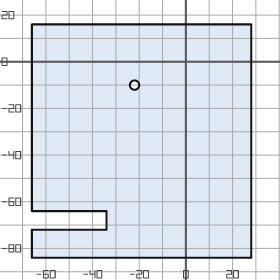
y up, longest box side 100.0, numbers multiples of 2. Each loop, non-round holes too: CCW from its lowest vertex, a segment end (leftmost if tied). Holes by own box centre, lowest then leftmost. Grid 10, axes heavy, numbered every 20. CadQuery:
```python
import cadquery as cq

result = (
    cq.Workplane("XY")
    .moveTo(-66.0, -84.0)
    .lineTo(28.0, -84.0)
    .lineTo(28.0, 16.0)
    .lineTo(-66.0, 16.0)
    .lineTo(-66.0, -64.0)
    .lineTo(-34.0, -64.0)
    .lineTo(-34.0, -72.0)
    .lineTo(-66.0, -72.0)
    .close()
    .moveTo(-22.0, -10.0)
    .circle(2.0)
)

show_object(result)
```